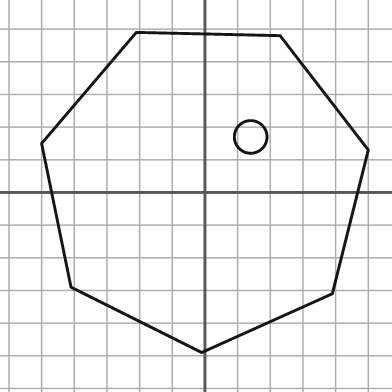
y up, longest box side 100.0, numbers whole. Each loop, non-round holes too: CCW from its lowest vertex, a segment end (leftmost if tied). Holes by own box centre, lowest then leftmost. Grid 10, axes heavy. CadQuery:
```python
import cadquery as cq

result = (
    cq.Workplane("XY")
    .moveTo(-1.0, -49.0)
    .lineTo(39.0, -31.0)
    .lineTo(50.0, 13.0)
    .lineTo(23.0, 48.0)
    .lineTo(-21.0, 49.0)
    .lineTo(-50.0, 15.0)
    .lineTo(-41.0, -29.0)
    .close()
    .moveTo(14.0, 17.0)
    .circle(5.0)
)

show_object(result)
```